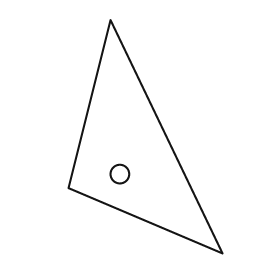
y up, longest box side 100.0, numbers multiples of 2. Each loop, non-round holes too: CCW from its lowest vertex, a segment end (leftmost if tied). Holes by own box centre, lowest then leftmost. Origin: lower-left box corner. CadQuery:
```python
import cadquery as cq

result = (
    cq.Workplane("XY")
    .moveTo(66.0, 0.0)
    .lineTo(18.0, 100.0)
    .lineTo(0.0, 28.0)
    .close()
    .moveTo(22.0, 34.0)
    .circle(4.0)
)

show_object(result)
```